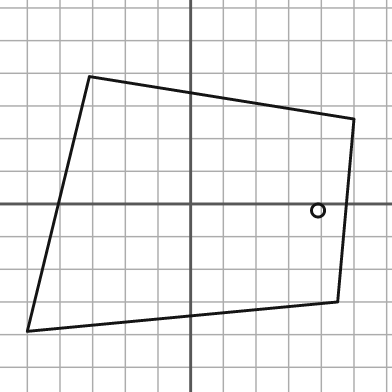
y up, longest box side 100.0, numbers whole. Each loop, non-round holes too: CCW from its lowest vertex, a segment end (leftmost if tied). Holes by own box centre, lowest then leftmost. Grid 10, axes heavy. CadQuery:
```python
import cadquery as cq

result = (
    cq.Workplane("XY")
    .moveTo(-50.0, -39.0)
    .lineTo(45.0, -30.0)
    .lineTo(50.0, 26.0)
    .lineTo(-31.0, 39.0)
    .close()
    .moveTo(39.0, -2.0)
    .circle(2.0)
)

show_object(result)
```